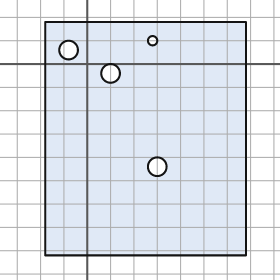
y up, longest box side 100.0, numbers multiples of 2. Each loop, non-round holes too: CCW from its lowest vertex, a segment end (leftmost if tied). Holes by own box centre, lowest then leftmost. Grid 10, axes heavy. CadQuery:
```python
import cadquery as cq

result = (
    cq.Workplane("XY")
    .moveTo(-18.0, -82.0)
    .lineTo(68.0, -82.0)
    .lineTo(68.0, 18.0)
    .lineTo(-18.0, 18.0)
    .close()
    .moveTo(30.0, -44.0)
    .circle(4.0)
    .moveTo(10.0, -4.0)
    .circle(4.0)
    .moveTo(-8.0, 6.0)
    .circle(4.0)
    .moveTo(28.0, 10.0)
    .circle(2.0)
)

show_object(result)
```